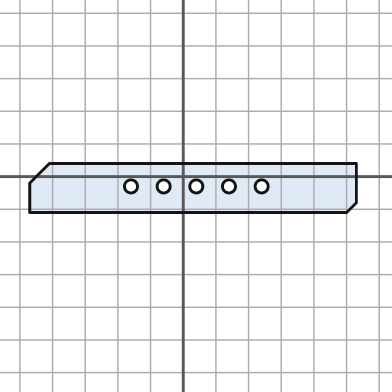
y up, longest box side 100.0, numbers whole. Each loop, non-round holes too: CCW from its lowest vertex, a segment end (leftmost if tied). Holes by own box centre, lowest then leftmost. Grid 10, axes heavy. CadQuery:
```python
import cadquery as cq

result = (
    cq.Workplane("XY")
    .moveTo(-47.0, -11.0)
    .lineTo(50.0, -11.0)
    .lineTo(53.0, -8.0)
    .lineTo(53.0, 4.0)
    .lineTo(-41.0, 4.0)
    .lineTo(-47.0, -2.0)
    .close()
    .moveTo(-16.0, -3.0)
    .circle(2.0)
    .moveTo(-6.0, -3.0)
    .circle(2.0)
    .moveTo(4.0, -3.0)
    .circle(2.0)
    .moveTo(14.0, -3.0)
    .circle(2.0)
    .moveTo(24.0, -3.0)
    .circle(2.0)
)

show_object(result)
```